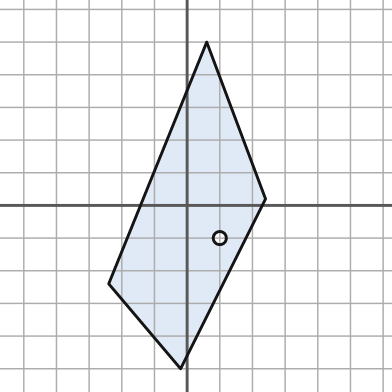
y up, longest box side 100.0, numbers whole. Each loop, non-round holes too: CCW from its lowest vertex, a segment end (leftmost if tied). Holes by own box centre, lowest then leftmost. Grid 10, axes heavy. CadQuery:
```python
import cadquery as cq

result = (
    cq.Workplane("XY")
    .moveTo(-2.0, -50.0)
    .lineTo(24.0, 2.0)
    .lineTo(6.0, 50.0)
    .lineTo(-24.0, -24.0)
    .close()
    .moveTo(10.0, -10.0)
    .circle(2.0)
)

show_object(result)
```